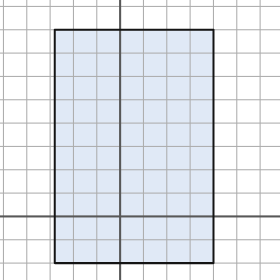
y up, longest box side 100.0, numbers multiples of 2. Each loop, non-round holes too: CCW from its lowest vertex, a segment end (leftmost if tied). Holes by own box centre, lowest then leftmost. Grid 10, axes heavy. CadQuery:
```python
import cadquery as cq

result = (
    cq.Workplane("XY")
    .moveTo(-28.0, -20.0)
    .lineTo(40.0, -20.0)
    .lineTo(40.0, 80.0)
    .lineTo(-28.0, 80.0)
    .close()
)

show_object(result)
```